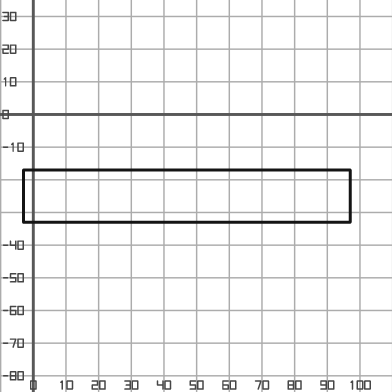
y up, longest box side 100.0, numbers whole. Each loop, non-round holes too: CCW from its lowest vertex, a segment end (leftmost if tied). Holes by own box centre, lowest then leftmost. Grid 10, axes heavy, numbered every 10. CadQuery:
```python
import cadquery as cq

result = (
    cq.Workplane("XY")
    .moveTo(-3.0, -33.0)
    .lineTo(97.0, -33.0)
    .lineTo(97.0, -17.0)
    .lineTo(-3.0, -17.0)
    .close()
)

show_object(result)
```